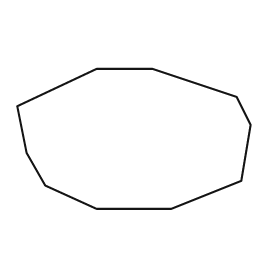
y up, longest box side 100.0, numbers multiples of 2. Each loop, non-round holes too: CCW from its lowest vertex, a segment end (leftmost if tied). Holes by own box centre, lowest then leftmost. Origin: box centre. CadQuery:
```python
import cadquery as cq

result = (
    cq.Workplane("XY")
    .moveTo(-16.0, -30.0)
    .lineTo(16.0, -30.0)
    .lineTo(46.0, -18.0)
    .lineTo(50.0, 6.0)
    .lineTo(44.0, 18.0)
    .lineTo(8.0, 30.0)
    .lineTo(-16.0, 30.0)
    .lineTo(-50.0, 14.0)
    .lineTo(-46.0, -6.0)
    .lineTo(-38.0, -20.0)
    .close()
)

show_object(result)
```